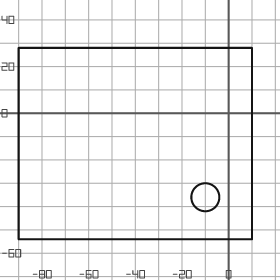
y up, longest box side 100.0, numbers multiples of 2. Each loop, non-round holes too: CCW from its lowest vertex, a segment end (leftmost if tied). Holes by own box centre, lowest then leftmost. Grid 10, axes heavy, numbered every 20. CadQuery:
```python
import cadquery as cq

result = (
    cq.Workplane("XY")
    .moveTo(-90.0, -54.0)
    .lineTo(10.0, -54.0)
    .lineTo(10.0, 28.0)
    .lineTo(-90.0, 28.0)
    .close()
    .moveTo(-10.0, -36.0)
    .circle(6.0)
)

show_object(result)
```